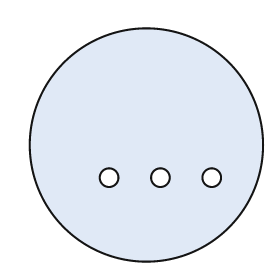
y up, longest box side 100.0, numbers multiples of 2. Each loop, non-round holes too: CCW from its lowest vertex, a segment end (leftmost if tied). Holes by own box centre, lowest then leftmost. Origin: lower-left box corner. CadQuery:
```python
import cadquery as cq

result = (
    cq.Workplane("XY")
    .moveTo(50.0, 50.0)
    .circle(50.0)
    .moveTo(34.0, 36.0)
    .circle(4.0)
    .moveTo(56.0, 36.0)
    .circle(4.0)
    .moveTo(78.0, 36.0)
    .circle(4.0)
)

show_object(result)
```